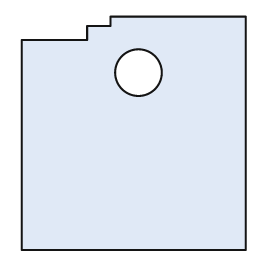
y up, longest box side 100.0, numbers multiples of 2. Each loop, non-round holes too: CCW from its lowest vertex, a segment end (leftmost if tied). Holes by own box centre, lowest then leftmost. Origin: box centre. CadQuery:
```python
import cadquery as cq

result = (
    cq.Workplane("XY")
    .moveTo(-48.0, -50.0)
    .lineTo(48.0, -50.0)
    .lineTo(48.0, 50.0)
    .lineTo(-10.0, 50.0)
    .lineTo(-10.0, 46.0)
    .lineTo(-20.0, 46.0)
    .lineTo(-20.0, 40.0)
    .lineTo(-48.0, 40.0)
    .close()
    .moveTo(2.0, 26.0)
    .circle(10.0)
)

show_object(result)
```